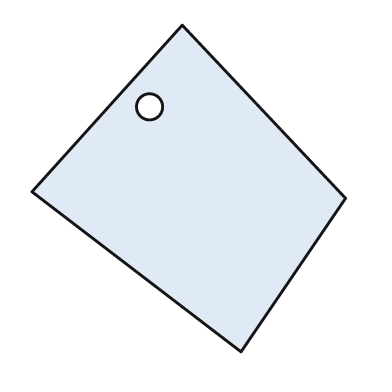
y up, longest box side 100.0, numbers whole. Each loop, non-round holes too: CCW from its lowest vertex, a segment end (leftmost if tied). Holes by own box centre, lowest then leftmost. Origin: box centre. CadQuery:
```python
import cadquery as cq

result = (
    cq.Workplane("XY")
    .moveTo(16.0, -50.0)
    .lineTo(48.0, -3.0)
    .lineTo(-2.0, 50.0)
    .lineTo(-48.0, -1.0)
    .close()
    .moveTo(-12.0, 25.0)
    .circle(4.0)
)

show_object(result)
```